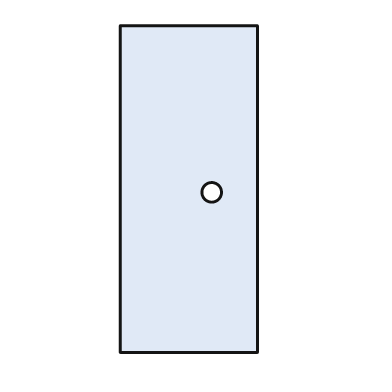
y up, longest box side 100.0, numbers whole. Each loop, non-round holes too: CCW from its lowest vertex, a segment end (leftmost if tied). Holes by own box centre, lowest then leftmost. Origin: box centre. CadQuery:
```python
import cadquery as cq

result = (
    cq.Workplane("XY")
    .moveTo(-21.0, -50.0)
    .lineTo(21.0, -50.0)
    .lineTo(21.0, 50.0)
    .lineTo(-21.0, 50.0)
    .close()
    .moveTo(7.0, -1.0)
    .circle(3.0)
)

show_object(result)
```